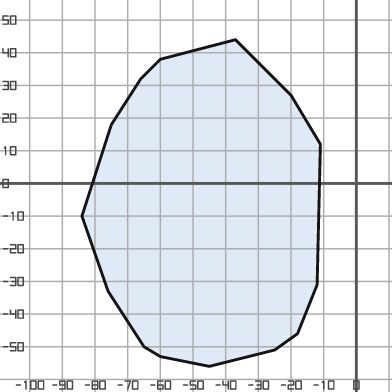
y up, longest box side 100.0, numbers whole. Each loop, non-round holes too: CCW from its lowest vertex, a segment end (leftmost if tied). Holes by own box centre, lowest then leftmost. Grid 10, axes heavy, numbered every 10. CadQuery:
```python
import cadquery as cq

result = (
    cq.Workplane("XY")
    .moveTo(-45.0, -56.0)
    .lineTo(-25.0, -51.0)
    .lineTo(-18.0, -46.0)
    .lineTo(-12.0, -31.0)
    .lineTo(-11.0, 12.0)
    .lineTo(-20.0, 27.0)
    .lineTo(-37.0, 44.0)
    .lineTo(-60.0, 38.0)
    .lineTo(-66.0, 32.0)
    .lineTo(-75.0, 18.0)
    .lineTo(-84.0, -10.0)
    .lineTo(-76.0, -33.0)
    .lineTo(-65.0, -50.0)
    .lineTo(-60.0, -53.0)
    .close()
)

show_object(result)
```